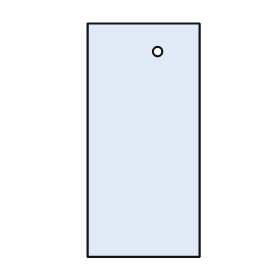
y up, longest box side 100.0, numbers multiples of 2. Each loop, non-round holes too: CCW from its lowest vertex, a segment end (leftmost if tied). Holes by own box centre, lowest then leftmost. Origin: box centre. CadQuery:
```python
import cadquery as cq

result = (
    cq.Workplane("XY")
    .moveTo(-24.0, -50.0)
    .lineTo(24.0, -50.0)
    .lineTo(24.0, 50.0)
    .lineTo(-24.0, 50.0)
    .close()
    .moveTo(6.0, 38.0)
    .circle(2.0)
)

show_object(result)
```